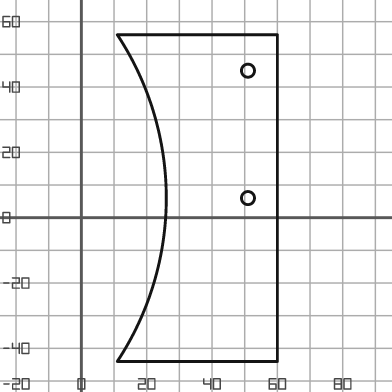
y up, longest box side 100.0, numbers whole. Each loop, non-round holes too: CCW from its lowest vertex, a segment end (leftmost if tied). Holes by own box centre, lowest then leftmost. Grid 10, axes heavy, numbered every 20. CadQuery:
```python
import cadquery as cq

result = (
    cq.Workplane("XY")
    .moveTo(11.0, -44.0)
    .lineTo(60.0, -44.0)
    .lineTo(60.0, 56.0)
    .lineTo(11.0, 56.0)
    .threePointArc((26.0, 6.0), (11.0, -44.0))
    .close()
    .moveTo(51.0, 6.0)
    .circle(2.0)
    .moveTo(51.0, 45.0)
    .circle(2.0)
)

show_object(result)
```